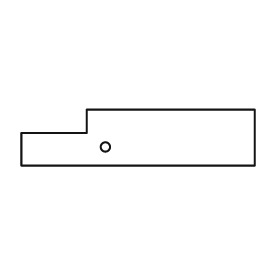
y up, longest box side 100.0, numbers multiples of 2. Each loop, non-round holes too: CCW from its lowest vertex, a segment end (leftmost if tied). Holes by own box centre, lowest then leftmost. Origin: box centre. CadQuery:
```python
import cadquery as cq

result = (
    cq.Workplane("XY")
    .moveTo(-50.0, -12.0)
    .lineTo(50.0, -12.0)
    .lineTo(50.0, 12.0)
    .lineTo(-22.0, 12.0)
    .lineTo(-22.0, 2.0)
    .lineTo(-50.0, 2.0)
    .close()
    .moveTo(-14.0, -4.0)
    .circle(2.0)
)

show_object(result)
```